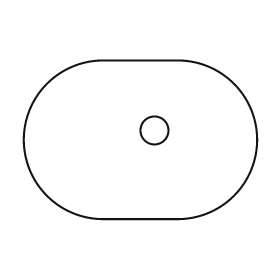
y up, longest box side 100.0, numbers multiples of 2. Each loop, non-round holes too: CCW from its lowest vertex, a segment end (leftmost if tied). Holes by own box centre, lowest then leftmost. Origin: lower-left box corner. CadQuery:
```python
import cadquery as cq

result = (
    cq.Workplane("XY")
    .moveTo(34.0, 0.0)
    .lineTo(66.0, 0.0)
    .threePointArc((100.0, 34.0), (66.0, 68.0))
    .lineTo(34.0, 68.0)
    .threePointArc((0.0, 34.0), (34.0, 0.0))
    .close()
    .moveTo(56.0, 38.0)
    .circle(6.0)
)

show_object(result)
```